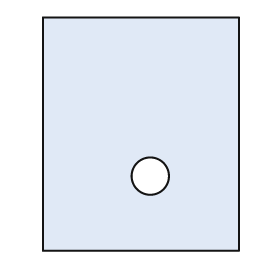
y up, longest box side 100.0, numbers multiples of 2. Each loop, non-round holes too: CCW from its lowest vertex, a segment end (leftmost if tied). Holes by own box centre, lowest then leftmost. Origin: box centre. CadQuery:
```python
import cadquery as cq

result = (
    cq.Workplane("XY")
    .moveTo(-42.0, -50.0)
    .lineTo(42.0, -50.0)
    .lineTo(42.0, 50.0)
    .lineTo(-42.0, 50.0)
    .close()
    .moveTo(4.0, -18.0)
    .circle(8.0)
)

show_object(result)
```